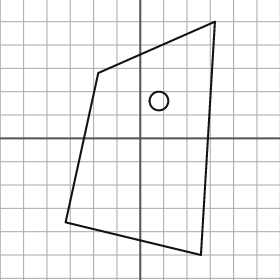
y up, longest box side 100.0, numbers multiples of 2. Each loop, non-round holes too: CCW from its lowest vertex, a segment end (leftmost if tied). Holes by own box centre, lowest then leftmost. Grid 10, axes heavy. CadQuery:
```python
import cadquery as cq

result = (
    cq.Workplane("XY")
    .moveTo(26.0, -50.0)
    .lineTo(32.0, 50.0)
    .lineTo(-18.0, 28.0)
    .lineTo(-32.0, -36.0)
    .close()
    .moveTo(8.0, 16.0)
    .circle(4.0)
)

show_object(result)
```